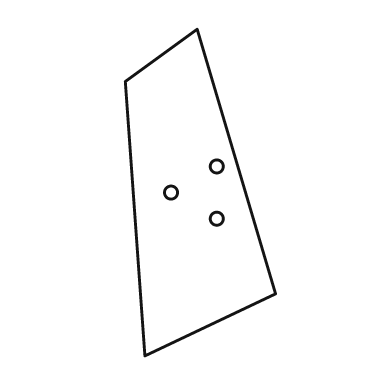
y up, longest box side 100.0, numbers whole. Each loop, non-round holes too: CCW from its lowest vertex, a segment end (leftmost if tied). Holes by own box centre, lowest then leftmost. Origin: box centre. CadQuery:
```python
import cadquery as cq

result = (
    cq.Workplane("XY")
    .moveTo(-17.0, -50.0)
    .lineTo(23.0, -31.0)
    .lineTo(-1.0, 50.0)
    .lineTo(-23.0, 34.0)
    .close()
    .moveTo(5.0, -8.0)
    .circle(2.0)
    .moveTo(-9.0, 0.0)
    .circle(2.0)
    .moveTo(5.0, 8.0)
    .circle(2.0)
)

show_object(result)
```